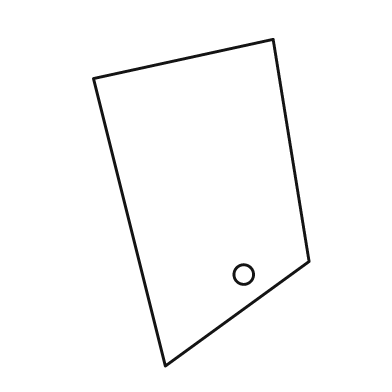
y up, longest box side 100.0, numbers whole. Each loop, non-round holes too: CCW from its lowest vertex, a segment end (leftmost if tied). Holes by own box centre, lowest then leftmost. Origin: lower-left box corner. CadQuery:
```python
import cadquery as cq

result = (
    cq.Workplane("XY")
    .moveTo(22.0, 0.0)
    .lineTo(66.0, 32.0)
    .lineTo(55.0, 100.0)
    .lineTo(0.0, 88.0)
    .close()
    .moveTo(46.0, 28.0)
    .circle(3.0)
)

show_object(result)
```